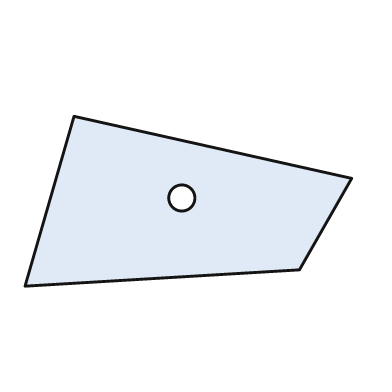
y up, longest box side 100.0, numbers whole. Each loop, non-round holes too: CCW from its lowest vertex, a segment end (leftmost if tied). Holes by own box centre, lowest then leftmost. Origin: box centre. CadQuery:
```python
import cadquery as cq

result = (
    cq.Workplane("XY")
    .moveTo(-50.0, -26.0)
    .lineTo(34.0, -21.0)
    .lineTo(50.0, 7.0)
    .lineTo(-35.0, 26.0)
    .close()
    .moveTo(-2.0, 1.0)
    .circle(4.0)
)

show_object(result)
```